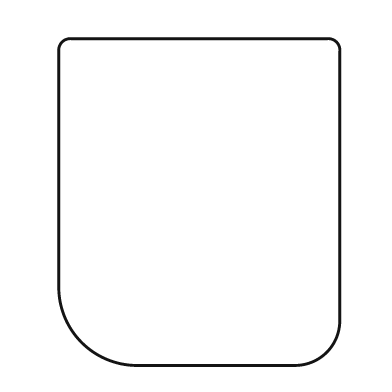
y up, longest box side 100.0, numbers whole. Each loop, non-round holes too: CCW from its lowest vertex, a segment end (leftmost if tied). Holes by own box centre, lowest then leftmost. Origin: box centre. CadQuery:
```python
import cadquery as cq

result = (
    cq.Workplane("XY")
    .moveTo(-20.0, -50.0)
    .lineTo(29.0, -50.0)
    .threePointArc((39.0, -46.0), (43.0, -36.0))
    .lineTo(43.0, 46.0)
    .threePointArc((42.0, 49.0), (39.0, 50.0))
    .lineTo(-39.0, 50.0)
    .threePointArc((-42.0, 49.0), (-43.0, 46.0))
    .lineTo(-43.0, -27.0)
    .threePointArc((-36.0, -43.0), (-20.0, -50.0))
    .close()
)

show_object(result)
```